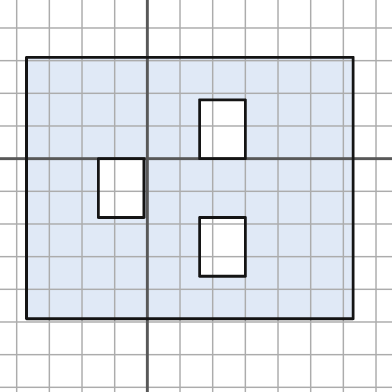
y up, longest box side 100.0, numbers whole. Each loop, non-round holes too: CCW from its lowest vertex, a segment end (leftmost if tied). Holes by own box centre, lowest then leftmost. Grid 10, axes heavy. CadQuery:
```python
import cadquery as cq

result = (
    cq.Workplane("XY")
    .moveTo(-37.0, -49.0)
    .lineTo(63.0, -49.0)
    .lineTo(63.0, 31.0)
    .lineTo(-37.0, 31.0)
    .close()
    .moveTo(16.0, -36.0)
    .lineTo(30.0, -36.0)
    .lineTo(30.0, -18.0)
    .lineTo(16.0, -18.0)
    .close()
    .moveTo(-15.0, -18.0)
    .lineTo(-1.0, -18.0)
    .lineTo(-1.0, 0.0)
    .lineTo(-15.0, 0.0)
    .close()
    .moveTo(16.0, 0.0)
    .lineTo(30.0, 0.0)
    .lineTo(30.0, 18.0)
    .lineTo(16.0, 18.0)
    .close()
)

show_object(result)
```